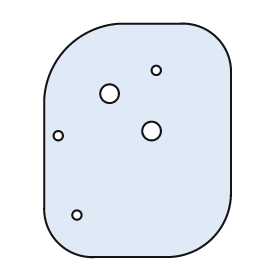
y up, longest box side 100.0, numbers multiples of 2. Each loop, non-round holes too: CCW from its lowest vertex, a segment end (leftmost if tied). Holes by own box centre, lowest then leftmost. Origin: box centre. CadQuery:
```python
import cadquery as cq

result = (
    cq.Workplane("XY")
    .moveTo(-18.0, -50.0)
    .lineTo(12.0, -50.0)
    .threePointArc((32.0, -42.0), (40.0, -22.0))
    .lineTo(40.0, 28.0)
    .threePointArc((34.0, 44.0), (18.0, 50.0))
    .lineTo(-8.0, 50.0)
    .threePointArc((-30.0, 40.0), (-40.0, 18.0))
    .lineTo(-40.0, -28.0)
    .threePointArc((-34.0, -44.0), (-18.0, -50.0))
    .close()
    .moveTo(-26.0, -32.0)
    .circle(2.0)
    .moveTo(-34.0, 2.0)
    .circle(2.0)
    .moveTo(6.0, 4.0)
    .circle(4.0)
    .moveTo(-12.0, 20.0)
    .circle(4.0)
    .moveTo(8.0, 30.0)
    .circle(2.0)
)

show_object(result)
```